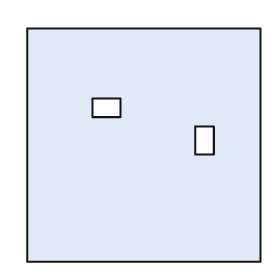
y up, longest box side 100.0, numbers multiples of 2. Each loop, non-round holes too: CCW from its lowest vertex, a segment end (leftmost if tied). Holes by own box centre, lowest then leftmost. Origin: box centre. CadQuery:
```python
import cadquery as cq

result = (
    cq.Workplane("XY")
    .moveTo(-50.0, -50.0)
    .lineTo(50.0, -50.0)
    .lineTo(50.0, 50.0)
    .lineTo(-50.0, 50.0)
    .close()
    .moveTo(22.0, -4.0)
    .lineTo(30.0, -4.0)
    .lineTo(30.0, 8.0)
    .lineTo(22.0, 8.0)
    .close()
    .moveTo(-22.0, 12.0)
    .lineTo(-10.0, 12.0)
    .lineTo(-10.0, 20.0)
    .lineTo(-22.0, 20.0)
    .close()
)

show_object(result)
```